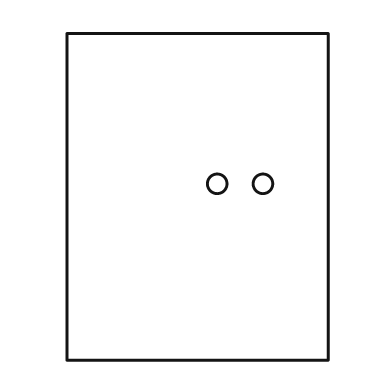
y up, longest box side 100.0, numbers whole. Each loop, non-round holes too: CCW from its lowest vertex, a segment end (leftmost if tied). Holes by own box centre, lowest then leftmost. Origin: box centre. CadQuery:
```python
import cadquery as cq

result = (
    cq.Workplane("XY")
    .moveTo(-40.0, -50.0)
    .lineTo(40.0, -50.0)
    .lineTo(40.0, 50.0)
    .lineTo(-40.0, 50.0)
    .close()
    .moveTo(6.0, 4.0)
    .circle(3.0)
    .moveTo(20.0, 4.0)
    .circle(3.0)
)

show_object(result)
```